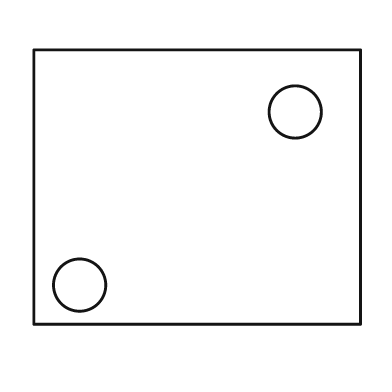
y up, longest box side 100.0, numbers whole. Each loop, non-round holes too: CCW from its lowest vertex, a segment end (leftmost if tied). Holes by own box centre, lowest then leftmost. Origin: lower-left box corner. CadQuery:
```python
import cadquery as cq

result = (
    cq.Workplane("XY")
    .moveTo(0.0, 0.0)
    .lineTo(100.0, 0.0)
    .lineTo(100.0, 84.0)
    .lineTo(0.0, 84.0)
    .close()
    .moveTo(14.0, 12.0)
    .circle(8.0)
    .moveTo(80.0, 65.0)
    .circle(8.0)
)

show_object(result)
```